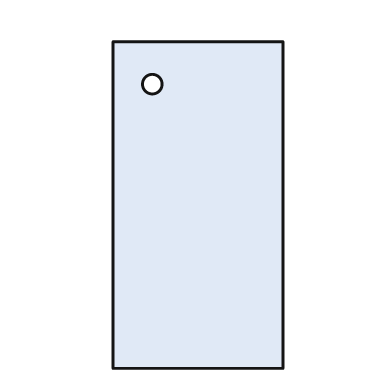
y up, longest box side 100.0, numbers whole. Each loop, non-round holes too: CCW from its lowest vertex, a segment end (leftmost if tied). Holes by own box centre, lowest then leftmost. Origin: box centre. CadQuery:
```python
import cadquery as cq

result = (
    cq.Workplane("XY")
    .moveTo(-26.0, -50.0)
    .lineTo(26.0, -50.0)
    .lineTo(26.0, 50.0)
    .lineTo(-26.0, 50.0)
    .close()
    .moveTo(-14.0, 37.0)
    .circle(3.0)
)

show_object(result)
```